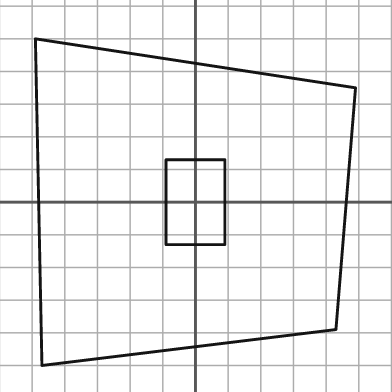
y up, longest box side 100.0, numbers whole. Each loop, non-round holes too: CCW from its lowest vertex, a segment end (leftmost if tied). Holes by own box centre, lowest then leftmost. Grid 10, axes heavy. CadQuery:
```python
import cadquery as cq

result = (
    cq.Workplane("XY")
    .moveTo(-47.0, -50.0)
    .lineTo(43.0, -39.0)
    .lineTo(49.0, 35.0)
    .lineTo(-49.0, 50.0)
    .close()
    .moveTo(-9.0, -13.0)
    .lineTo(9.0, -13.0)
    .lineTo(9.0, 13.0)
    .lineTo(-9.0, 13.0)
    .close()
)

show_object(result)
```